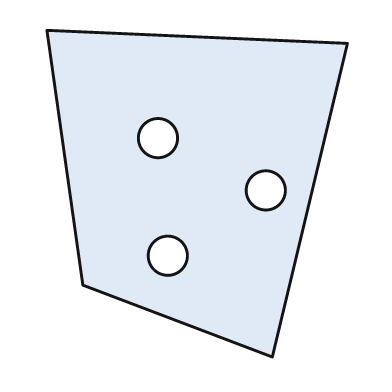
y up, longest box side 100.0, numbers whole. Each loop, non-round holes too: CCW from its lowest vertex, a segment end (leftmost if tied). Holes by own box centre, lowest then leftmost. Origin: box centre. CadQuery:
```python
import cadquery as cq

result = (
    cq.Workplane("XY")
    .moveTo(23.0, -50.0)
    .lineTo(46.0, 46.0)
    .lineTo(-46.0, 50.0)
    .lineTo(-35.0, -28.0)
    .close()
    .moveTo(-9.0, -19.0)
    .circle(6.0)
    .moveTo(21.0, 1.0)
    .circle(6.0)
    .moveTo(-12.0, 17.0)
    .circle(6.0)
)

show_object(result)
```